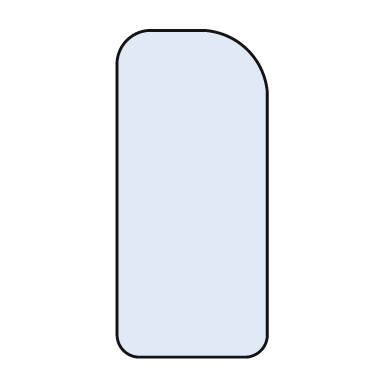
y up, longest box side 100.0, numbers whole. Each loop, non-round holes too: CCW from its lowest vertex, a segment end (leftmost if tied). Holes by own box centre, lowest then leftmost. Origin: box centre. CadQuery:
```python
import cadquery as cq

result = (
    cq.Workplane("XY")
    .moveTo(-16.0, -50.0)
    .lineTo(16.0, -50.0)
    .threePointArc((21.0, -48.0), (23.0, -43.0))
    .lineTo(23.0, 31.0)
    .threePointArc((17.0, 44.0), (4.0, 50.0))
    .lineTo(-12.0, 50.0)
    .threePointArc((-20.0, 47.0), (-23.0, 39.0))
    .lineTo(-23.0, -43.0)
    .threePointArc((-21.0, -48.0), (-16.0, -50.0))
    .close()
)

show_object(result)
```